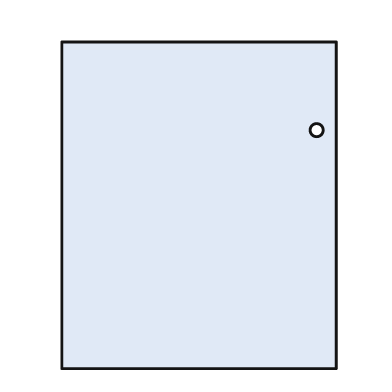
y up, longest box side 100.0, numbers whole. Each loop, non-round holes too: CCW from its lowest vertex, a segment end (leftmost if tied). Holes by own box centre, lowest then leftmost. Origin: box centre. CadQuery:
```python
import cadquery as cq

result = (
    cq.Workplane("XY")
    .moveTo(-42.0, -50.0)
    .lineTo(42.0, -50.0)
    .lineTo(42.0, 50.0)
    .lineTo(-42.0, 50.0)
    .close()
    .moveTo(36.0, 23.0)
    .circle(2.0)
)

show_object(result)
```